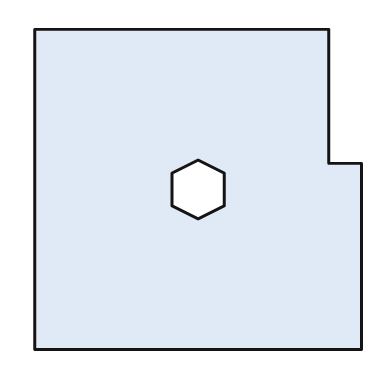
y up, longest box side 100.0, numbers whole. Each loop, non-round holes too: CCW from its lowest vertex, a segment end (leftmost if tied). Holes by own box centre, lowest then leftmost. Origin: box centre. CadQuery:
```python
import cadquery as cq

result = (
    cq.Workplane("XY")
    .moveTo(-50.0, -49.0)
    .lineTo(50.0, -49.0)
    .lineTo(50.0, 8.0)
    .lineTo(40.0, 8.0)
    .lineTo(40.0, 49.0)
    .lineTo(-50.0, 49.0)
    .close()
    .moveTo(0.0, -9.0)
    .lineTo(8.0, -5.0)
    .lineTo(8.0, 5.0)
    .lineTo(0.0, 9.0)
    .lineTo(-8.0, 5.0)
    .lineTo(-8.0, -5.0)
    .close()
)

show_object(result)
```